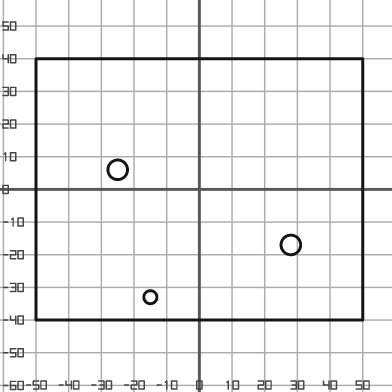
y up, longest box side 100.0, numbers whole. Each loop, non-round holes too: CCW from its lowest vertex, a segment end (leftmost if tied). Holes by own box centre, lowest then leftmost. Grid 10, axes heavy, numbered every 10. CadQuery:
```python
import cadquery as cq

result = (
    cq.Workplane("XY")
    .moveTo(-50.0, -40.0)
    .lineTo(50.0, -40.0)
    .lineTo(50.0, 40.0)
    .lineTo(-50.0, 40.0)
    .close()
    .moveTo(-15.0, -33.0)
    .circle(2.0)
    .moveTo(28.0, -17.0)
    .circle(3.0)
    .moveTo(-25.0, 6.0)
    .circle(3.0)
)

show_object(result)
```